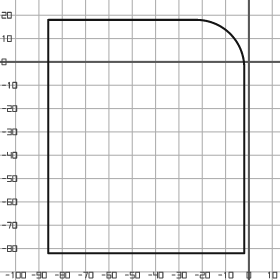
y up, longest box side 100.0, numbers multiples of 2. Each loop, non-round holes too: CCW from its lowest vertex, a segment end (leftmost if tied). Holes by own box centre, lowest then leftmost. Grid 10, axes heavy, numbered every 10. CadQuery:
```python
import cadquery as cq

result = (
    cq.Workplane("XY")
    .moveTo(-86.0, -82.0)
    .lineTo(-2.0, -82.0)
    .lineTo(-2.0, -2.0)
    .threePointArc((-8.0, 12.0), (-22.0, 18.0))
    .lineTo(-86.0, 18.0)
    .close()
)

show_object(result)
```